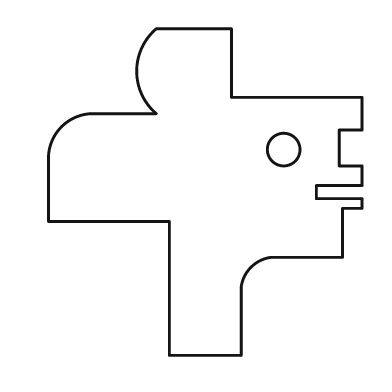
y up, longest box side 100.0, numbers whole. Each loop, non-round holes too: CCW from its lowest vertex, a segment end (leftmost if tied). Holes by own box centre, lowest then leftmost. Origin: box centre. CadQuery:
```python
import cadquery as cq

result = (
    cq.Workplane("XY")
    .moveTo(-11.0, -50.0)
    .lineTo(11.0, -50.0)
    .lineTo(11.0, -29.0)
    .threePointArc((14.0, -23.0), (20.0, -20.0))
    .lineTo(42.0, -20.0)
    .lineTo(42.0, -5.0)
    .lineTo(48.0, -5.0)
    .lineTo(48.0, -2.0)
    .lineTo(34.0, -2.0)
    .lineTo(34.0, 2.0)
    .lineTo(48.0, 2.0)
    .lineTo(48.0, 8.0)
    .lineTo(41.0, 8.0)
    .lineTo(41.0, 19.0)
    .lineTo(48.0, 19.0)
    .lineTo(48.0, 29.0)
    .lineTo(8.0, 29.0)
    .lineTo(8.0, 50.0)
    .lineTo(-15.0, 50.0)
    .threePointArc((-21.0, 37.0), (-15.0, 24.0))
    .lineTo(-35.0, 24.0)
    .threePointArc((-44.0, 20.0), (-48.0, 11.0))
    .lineTo(-48.0, -9.0)
    .lineTo(-11.0, -9.0)
    .close()
    .moveTo(24.0, 13.0)
    .circle(5.0)
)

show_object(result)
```